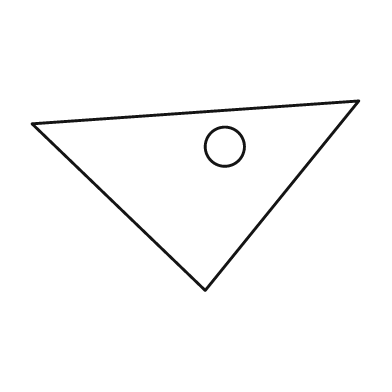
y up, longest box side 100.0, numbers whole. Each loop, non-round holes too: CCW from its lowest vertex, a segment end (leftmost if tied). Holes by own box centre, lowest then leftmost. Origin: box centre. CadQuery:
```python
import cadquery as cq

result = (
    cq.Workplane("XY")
    .moveTo(3.0, -29.0)
    .lineTo(50.0, 29.0)
    .lineTo(-50.0, 22.0)
    .close()
    .moveTo(9.0, 15.0)
    .circle(6.0)
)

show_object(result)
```